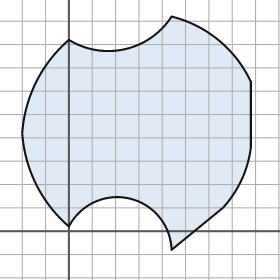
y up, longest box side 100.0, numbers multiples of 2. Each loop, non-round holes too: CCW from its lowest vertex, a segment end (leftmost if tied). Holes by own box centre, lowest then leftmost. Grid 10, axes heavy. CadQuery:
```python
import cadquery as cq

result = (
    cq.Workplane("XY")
    .moveTo(44.0, -8.0)
    .lineTo(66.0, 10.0)
    .threePointArc((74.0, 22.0), (78.0, 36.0))
    .lineTo(78.0, 64.0)
    .threePointArc((64.0, 82.0), (44.0, 92.0))
    .threePointArc((24.0, 78.0), (0.0, 82.0))
    .threePointArc((-14.0, 64.0), (-20.0, 42.0))
    .threePointArc((-14.0, 20.0), (0.0, 2.0))
    .threePointArc((26.0, 14.0), (44.0, -8.0))
    .close()
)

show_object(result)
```